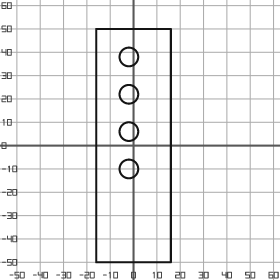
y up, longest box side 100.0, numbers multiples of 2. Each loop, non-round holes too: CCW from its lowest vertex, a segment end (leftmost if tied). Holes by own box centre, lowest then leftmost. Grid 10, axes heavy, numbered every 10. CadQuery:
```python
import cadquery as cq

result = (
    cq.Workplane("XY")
    .moveTo(-16.0, -50.0)
    .lineTo(16.0, -50.0)
    .lineTo(16.0, 50.0)
    .lineTo(-16.0, 50.0)
    .close()
    .moveTo(-2.0, -10.0)
    .circle(4.0)
    .moveTo(-2.0, 6.0)
    .circle(4.0)
    .moveTo(-2.0, 22.0)
    .circle(4.0)
    .moveTo(-2.0, 38.0)
    .circle(4.0)
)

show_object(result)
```